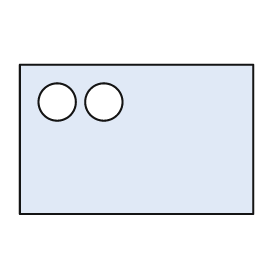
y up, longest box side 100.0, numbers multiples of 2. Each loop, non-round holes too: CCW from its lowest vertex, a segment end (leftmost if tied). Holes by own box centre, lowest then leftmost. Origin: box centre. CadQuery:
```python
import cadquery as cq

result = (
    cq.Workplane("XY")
    .moveTo(-50.0, -32.0)
    .lineTo(50.0, -32.0)
    .lineTo(50.0, 32.0)
    .lineTo(-50.0, 32.0)
    .close()
    .moveTo(-34.0, 16.0)
    .circle(8.0)
    .moveTo(-14.0, 16.0)
    .circle(8.0)
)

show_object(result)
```